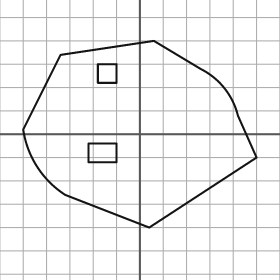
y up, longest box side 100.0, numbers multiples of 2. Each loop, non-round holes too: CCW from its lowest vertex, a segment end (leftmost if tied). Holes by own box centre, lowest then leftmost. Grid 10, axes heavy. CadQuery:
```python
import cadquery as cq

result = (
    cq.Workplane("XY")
    .moveTo(4.0, -40.0)
    .lineTo(50.0, -10.0)
    .lineTo(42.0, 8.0)
    .threePointArc((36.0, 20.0), (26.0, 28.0))
    .lineTo(6.0, 40.0)
    .lineTo(-34.0, 34.0)
    .lineTo(-50.0, 2.0)
    .threePointArc((-44.0, -14.0), (-32.0, -26.0))
    .close()
    .moveTo(-22.0, -12.0)
    .lineTo(-10.0, -12.0)
    .lineTo(-10.0, -4.0)
    .lineTo(-22.0, -4.0)
    .close()
    .moveTo(-18.0, 22.0)
    .lineTo(-10.0, 22.0)
    .lineTo(-10.0, 30.0)
    .lineTo(-18.0, 30.0)
    .close()
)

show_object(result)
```